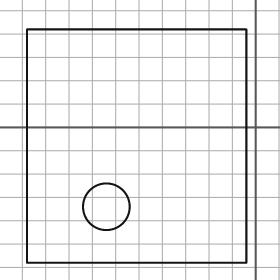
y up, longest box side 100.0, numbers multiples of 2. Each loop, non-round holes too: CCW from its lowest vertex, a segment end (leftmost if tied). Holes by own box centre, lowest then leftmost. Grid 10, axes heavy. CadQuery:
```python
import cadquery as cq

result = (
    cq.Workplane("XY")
    .moveTo(-98.0, -58.0)
    .lineTo(-4.0, -58.0)
    .lineTo(-4.0, 42.0)
    .lineTo(-98.0, 42.0)
    .close()
    .moveTo(-64.0, -34.0)
    .circle(10.0)
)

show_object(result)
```